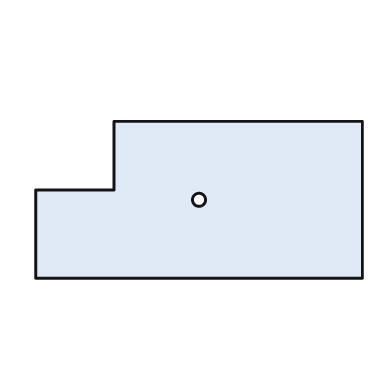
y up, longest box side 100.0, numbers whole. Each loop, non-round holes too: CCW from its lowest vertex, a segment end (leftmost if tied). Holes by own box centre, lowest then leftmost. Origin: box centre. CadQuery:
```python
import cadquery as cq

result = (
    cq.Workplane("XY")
    .moveTo(-50.0, -24.0)
    .lineTo(50.0, -24.0)
    .lineTo(50.0, 24.0)
    .lineTo(-26.0, 24.0)
    .lineTo(-26.0, 3.0)
    .lineTo(-50.0, 3.0)
    .close()
    .moveTo(0.0, 0.0)
    .circle(2.0)
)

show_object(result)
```